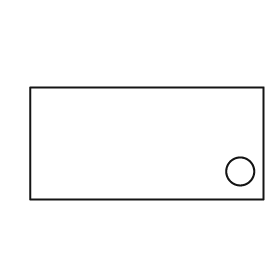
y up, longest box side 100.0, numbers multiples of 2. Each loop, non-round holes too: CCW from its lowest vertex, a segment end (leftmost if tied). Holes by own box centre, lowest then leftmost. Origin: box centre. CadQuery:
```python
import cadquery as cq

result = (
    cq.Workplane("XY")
    .moveTo(-50.0, -24.0)
    .lineTo(50.0, -24.0)
    .lineTo(50.0, 24.0)
    .lineTo(-50.0, 24.0)
    .close()
    .moveTo(40.0, -12.0)
    .circle(6.0)
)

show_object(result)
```